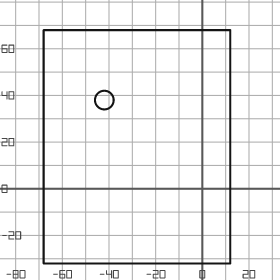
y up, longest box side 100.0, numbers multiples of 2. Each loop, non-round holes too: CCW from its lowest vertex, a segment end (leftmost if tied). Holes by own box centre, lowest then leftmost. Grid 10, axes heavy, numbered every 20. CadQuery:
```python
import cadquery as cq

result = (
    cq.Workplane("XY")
    .moveTo(-68.0, -32.0)
    .lineTo(12.0, -32.0)
    .lineTo(12.0, 68.0)
    .lineTo(-68.0, 68.0)
    .close()
    .moveTo(-42.0, 38.0)
    .circle(4.0)
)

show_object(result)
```